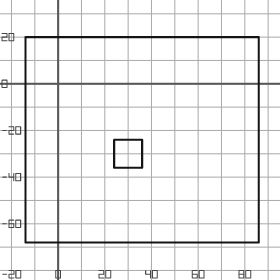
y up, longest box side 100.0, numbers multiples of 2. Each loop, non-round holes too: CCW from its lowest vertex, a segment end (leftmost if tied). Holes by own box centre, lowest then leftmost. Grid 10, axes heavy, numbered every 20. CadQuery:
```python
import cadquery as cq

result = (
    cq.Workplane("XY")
    .moveTo(-14.0, -68.0)
    .lineTo(86.0, -68.0)
    .lineTo(86.0, 20.0)
    .lineTo(-14.0, 20.0)
    .close()
    .moveTo(24.0, -36.0)
    .lineTo(36.0, -36.0)
    .lineTo(36.0, -24.0)
    .lineTo(24.0, -24.0)
    .close()
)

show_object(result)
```